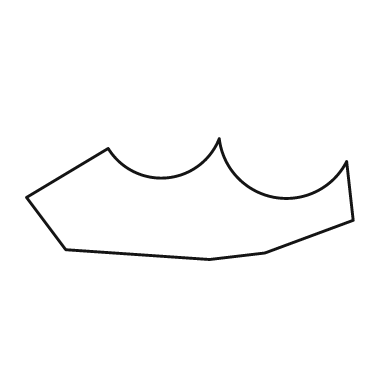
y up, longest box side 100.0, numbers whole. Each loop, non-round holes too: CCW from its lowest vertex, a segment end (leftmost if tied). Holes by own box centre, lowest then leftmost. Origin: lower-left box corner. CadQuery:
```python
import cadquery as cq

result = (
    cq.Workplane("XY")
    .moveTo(56.0, 0.0)
    .lineTo(73.0, 2.0)
    .lineTo(100.0, 12.0)
    .lineTo(98.0, 30.0)
    .threePointArc((76.0, 19.0), (59.0, 37.0))
    .threePointArc((43.0, 25.0), (25.0, 34.0))
    .lineTo(0.0, 19.0)
    .lineTo(12.0, 3.0)
    .close()
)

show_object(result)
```